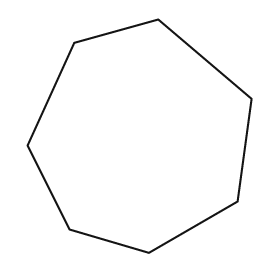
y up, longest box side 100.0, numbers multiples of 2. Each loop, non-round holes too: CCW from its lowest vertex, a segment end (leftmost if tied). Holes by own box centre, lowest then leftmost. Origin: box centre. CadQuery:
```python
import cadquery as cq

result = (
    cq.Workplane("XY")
    .moveTo(4.0, -50.0)
    .lineTo(42.0, -28.0)
    .lineTo(48.0, 16.0)
    .lineTo(8.0, 50.0)
    .lineTo(-28.0, 40.0)
    .lineTo(-48.0, -4.0)
    .lineTo(-30.0, -40.0)
    .close()
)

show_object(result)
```